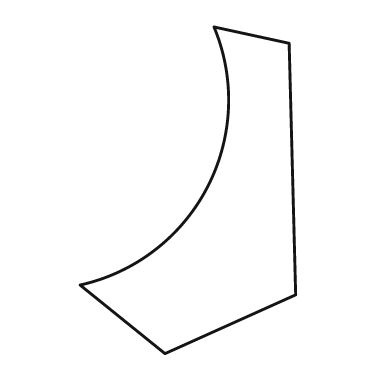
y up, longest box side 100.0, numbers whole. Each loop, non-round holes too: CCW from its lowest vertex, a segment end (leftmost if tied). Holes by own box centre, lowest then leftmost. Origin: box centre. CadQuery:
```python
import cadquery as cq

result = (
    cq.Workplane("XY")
    .moveTo(-7.0, -50.0)
    .lineTo(33.0, -32.0)
    .lineTo(31.0, 45.0)
    .lineTo(8.0, 50.0)
    .threePointArc((6.0, 1.0), (-33.0, -29.0))
    .close()
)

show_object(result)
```